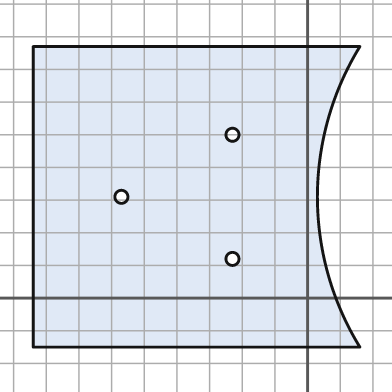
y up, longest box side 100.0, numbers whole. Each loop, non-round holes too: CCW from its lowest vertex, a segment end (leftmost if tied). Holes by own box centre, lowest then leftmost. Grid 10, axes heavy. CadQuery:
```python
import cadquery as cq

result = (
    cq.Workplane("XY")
    .moveTo(-84.0, -15.0)
    .lineTo(16.0, -15.0)
    .threePointArc((3.0, 31.0), (16.0, 77.0))
    .lineTo(-84.0, 77.0)
    .close()
    .moveTo(-23.0, 12.0)
    .circle(2.0)
    .moveTo(-57.0, 31.0)
    .circle(2.0)
    .moveTo(-23.0, 50.0)
    .circle(2.0)
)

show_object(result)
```